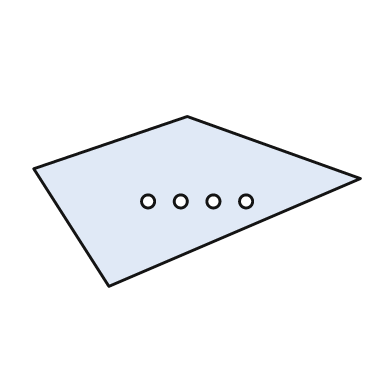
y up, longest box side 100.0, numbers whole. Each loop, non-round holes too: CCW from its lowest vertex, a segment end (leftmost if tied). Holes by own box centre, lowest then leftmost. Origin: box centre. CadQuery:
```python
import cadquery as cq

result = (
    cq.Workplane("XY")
    .moveTo(-27.0, -26.0)
    .lineTo(50.0, 7.0)
    .lineTo(-3.0, 26.0)
    .lineTo(-50.0, 10.0)
    .close()
    .moveTo(-15.0, 0.0)
    .circle(2.0)
    .moveTo(-5.0, 0.0)
    .circle(2.0)
    .moveTo(5.0, 0.0)
    .circle(2.0)
    .moveTo(15.0, 0.0)
    .circle(2.0)
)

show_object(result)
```